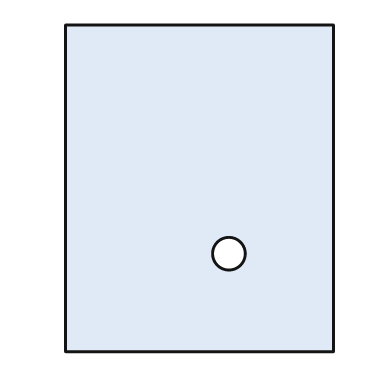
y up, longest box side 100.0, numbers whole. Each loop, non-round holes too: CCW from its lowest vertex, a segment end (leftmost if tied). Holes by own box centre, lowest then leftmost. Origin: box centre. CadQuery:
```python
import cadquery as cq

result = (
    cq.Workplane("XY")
    .moveTo(-41.0, -50.0)
    .lineTo(41.0, -50.0)
    .lineTo(41.0, 50.0)
    .lineTo(-41.0, 50.0)
    .close()
    .moveTo(9.0, -20.0)
    .circle(5.0)
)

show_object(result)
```